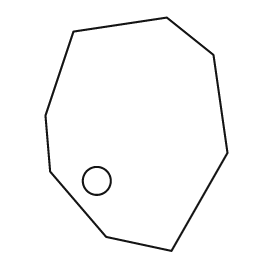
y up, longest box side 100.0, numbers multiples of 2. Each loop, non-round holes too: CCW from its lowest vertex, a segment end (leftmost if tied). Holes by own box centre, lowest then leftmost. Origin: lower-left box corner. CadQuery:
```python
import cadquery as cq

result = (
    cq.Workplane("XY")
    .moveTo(54.0, 0.0)
    .lineTo(78.0, 42.0)
    .lineTo(72.0, 84.0)
    .lineTo(52.0, 100.0)
    .lineTo(12.0, 94.0)
    .lineTo(0.0, 58.0)
    .lineTo(2.0, 34.0)
    .lineTo(26.0, 6.0)
    .close()
    .moveTo(22.0, 30.0)
    .circle(6.0)
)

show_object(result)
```